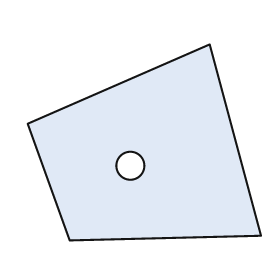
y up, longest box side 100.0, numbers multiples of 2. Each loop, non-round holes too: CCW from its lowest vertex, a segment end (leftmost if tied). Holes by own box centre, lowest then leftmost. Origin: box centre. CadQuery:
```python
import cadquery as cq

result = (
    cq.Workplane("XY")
    .moveTo(-32.0, -42.0)
    .lineTo(50.0, -40.0)
    .lineTo(28.0, 42.0)
    .lineTo(-50.0, 8.0)
    .close()
    .moveTo(-6.0, -10.0)
    .circle(6.0)
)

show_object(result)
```